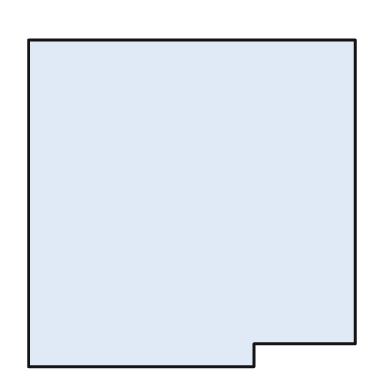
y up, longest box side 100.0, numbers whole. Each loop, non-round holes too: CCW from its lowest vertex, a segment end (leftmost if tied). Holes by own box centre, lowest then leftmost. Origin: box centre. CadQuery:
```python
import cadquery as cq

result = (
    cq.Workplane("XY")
    .moveTo(-50.0, -50.0)
    .lineTo(19.0, -50.0)
    .lineTo(19.0, -43.0)
    .lineTo(50.0, -43.0)
    .lineTo(50.0, 50.0)
    .lineTo(-50.0, 50.0)
    .close()
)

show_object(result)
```